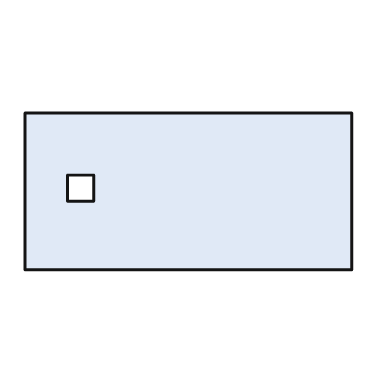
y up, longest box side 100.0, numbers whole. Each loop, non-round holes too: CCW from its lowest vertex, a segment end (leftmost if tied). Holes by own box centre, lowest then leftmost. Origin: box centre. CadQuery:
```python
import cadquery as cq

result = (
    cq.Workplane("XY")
    .moveTo(-50.0, -24.0)
    .lineTo(50.0, -24.0)
    .lineTo(50.0, 24.0)
    .lineTo(-50.0, 24.0)
    .close()
    .moveTo(-37.0, -3.0)
    .lineTo(-29.0, -3.0)
    .lineTo(-29.0, 5.0)
    .lineTo(-37.0, 5.0)
    .close()
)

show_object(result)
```